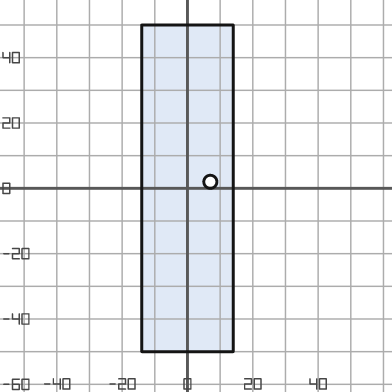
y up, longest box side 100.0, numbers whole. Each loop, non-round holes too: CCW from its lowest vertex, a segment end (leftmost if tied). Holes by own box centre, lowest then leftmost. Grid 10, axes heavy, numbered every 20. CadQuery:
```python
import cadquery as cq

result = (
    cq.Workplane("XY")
    .moveTo(-14.0, -50.0)
    .lineTo(14.0, -50.0)
    .lineTo(14.0, 50.0)
    .lineTo(-14.0, 50.0)
    .close()
    .moveTo(7.0, 2.0)
    .circle(2.0)
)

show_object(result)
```